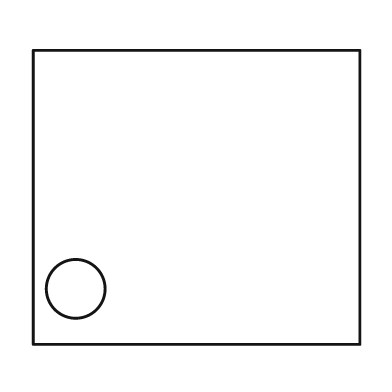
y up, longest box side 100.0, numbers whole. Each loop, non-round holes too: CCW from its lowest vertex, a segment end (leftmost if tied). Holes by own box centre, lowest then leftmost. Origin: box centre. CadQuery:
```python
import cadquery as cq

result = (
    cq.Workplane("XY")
    .moveTo(-50.0, -45.0)
    .lineTo(50.0, -45.0)
    .lineTo(50.0, 45.0)
    .lineTo(-50.0, 45.0)
    .close()
    .moveTo(-37.0, -28.0)
    .circle(9.0)
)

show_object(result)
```